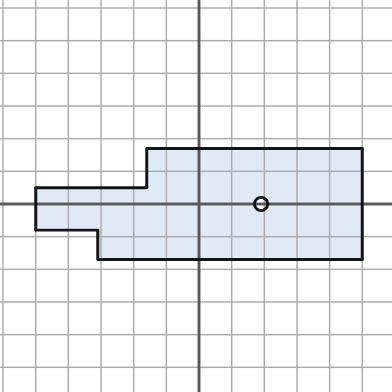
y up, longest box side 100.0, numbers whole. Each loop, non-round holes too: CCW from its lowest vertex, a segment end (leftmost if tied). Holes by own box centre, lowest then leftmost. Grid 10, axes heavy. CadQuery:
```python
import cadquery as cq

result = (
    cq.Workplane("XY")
    .moveTo(-31.0, -17.0)
    .lineTo(50.0, -17.0)
    .lineTo(50.0, 17.0)
    .lineTo(-16.0, 17.0)
    .lineTo(-16.0, 5.0)
    .lineTo(-50.0, 5.0)
    .lineTo(-50.0, -8.0)
    .lineTo(-31.0, -8.0)
    .close()
    .moveTo(19.0, 0.0)
    .circle(2.0)
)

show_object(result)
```